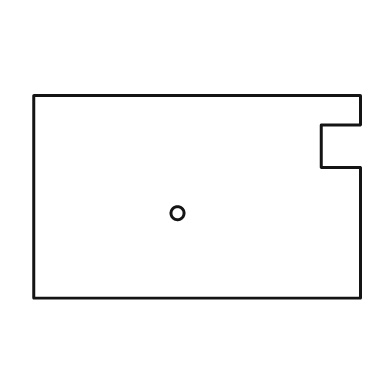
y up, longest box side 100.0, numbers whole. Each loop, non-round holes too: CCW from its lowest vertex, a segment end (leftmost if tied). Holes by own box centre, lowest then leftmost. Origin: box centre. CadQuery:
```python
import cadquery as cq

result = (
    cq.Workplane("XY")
    .moveTo(-50.0, -31.0)
    .lineTo(50.0, -31.0)
    .lineTo(50.0, 9.0)
    .lineTo(38.0, 9.0)
    .lineTo(38.0, 22.0)
    .lineTo(50.0, 22.0)
    .lineTo(50.0, 31.0)
    .lineTo(-50.0, 31.0)
    .close()
    .moveTo(-6.0, -5.0)
    .circle(2.0)
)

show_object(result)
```